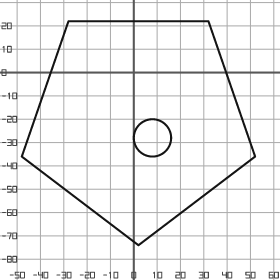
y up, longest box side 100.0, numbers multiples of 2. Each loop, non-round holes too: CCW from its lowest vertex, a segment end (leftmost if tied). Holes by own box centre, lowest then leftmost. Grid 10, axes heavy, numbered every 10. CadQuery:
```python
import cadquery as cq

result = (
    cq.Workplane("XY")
    .moveTo(2.0, -74.0)
    .lineTo(52.0, -36.0)
    .lineTo(32.0, 22.0)
    .lineTo(-28.0, 22.0)
    .lineTo(-48.0, -36.0)
    .close()
    .moveTo(8.0, -28.0)
    .circle(8.0)
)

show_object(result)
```